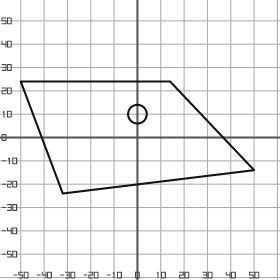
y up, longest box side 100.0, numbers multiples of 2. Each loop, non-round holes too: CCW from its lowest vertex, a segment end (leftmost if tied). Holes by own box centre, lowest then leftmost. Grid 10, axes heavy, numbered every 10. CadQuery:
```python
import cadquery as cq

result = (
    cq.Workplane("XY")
    .moveTo(-32.0, -24.0)
    .lineTo(50.0, -14.0)
    .lineTo(14.0, 24.0)
    .lineTo(-50.0, 24.0)
    .close()
    .moveTo(0.0, 10.0)
    .circle(4.0)
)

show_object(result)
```